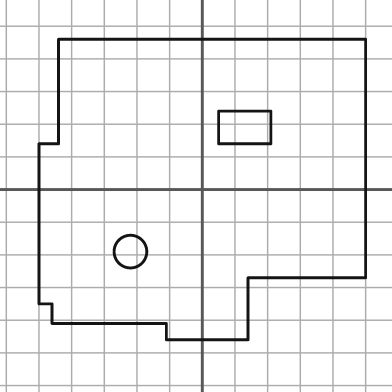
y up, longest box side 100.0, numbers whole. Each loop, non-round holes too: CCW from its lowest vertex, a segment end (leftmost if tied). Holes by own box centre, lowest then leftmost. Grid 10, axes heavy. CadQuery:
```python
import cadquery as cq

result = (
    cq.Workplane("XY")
    .moveTo(-11.0, -46.0)
    .lineTo(14.0, -46.0)
    .lineTo(14.0, -27.0)
    .lineTo(50.0, -27.0)
    .lineTo(50.0, 46.0)
    .lineTo(-44.0, 46.0)
    .lineTo(-44.0, 14.0)
    .lineTo(-50.0, 14.0)
    .lineTo(-50.0, -35.0)
    .lineTo(-46.0, -35.0)
    .lineTo(-46.0, -41.0)
    .lineTo(-11.0, -41.0)
    .close()
    .moveTo(-22.0, -19.0)
    .circle(5.0)
    .moveTo(5.0, 14.0)
    .lineTo(21.0, 14.0)
    .lineTo(21.0, 24.0)
    .lineTo(5.0, 24.0)
    .close()
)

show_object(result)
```